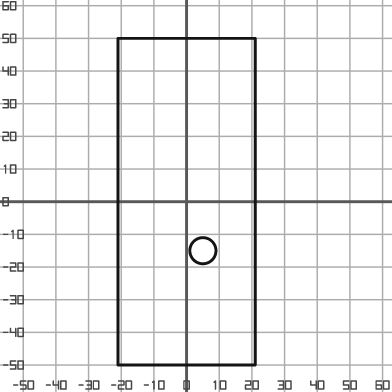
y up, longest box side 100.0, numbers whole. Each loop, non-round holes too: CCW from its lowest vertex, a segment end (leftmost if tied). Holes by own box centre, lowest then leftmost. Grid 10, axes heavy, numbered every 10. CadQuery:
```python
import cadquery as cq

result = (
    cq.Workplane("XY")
    .moveTo(-21.0, -50.0)
    .lineTo(21.0, -50.0)
    .lineTo(21.0, 50.0)
    .lineTo(-21.0, 50.0)
    .close()
    .moveTo(5.0, -15.0)
    .circle(4.0)
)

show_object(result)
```